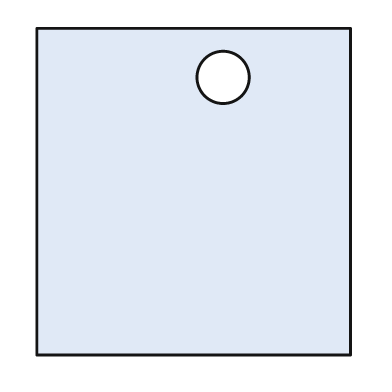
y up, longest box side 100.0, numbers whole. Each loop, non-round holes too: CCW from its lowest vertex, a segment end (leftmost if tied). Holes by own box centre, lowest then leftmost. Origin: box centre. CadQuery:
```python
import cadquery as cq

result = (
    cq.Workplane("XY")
    .moveTo(-48.0, -50.0)
    .lineTo(48.0, -50.0)
    .lineTo(48.0, 50.0)
    .lineTo(-48.0, 50.0)
    .close()
    .moveTo(9.0, 35.0)
    .circle(8.0)
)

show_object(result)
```